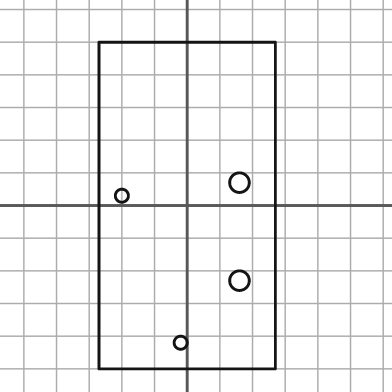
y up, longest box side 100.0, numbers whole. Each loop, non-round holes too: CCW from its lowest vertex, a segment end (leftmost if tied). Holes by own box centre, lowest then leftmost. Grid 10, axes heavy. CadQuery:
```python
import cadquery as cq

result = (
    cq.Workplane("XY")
    .moveTo(-27.0, -50.0)
    .lineTo(27.0, -50.0)
    .lineTo(27.0, 50.0)
    .lineTo(-27.0, 50.0)
    .close()
    .moveTo(-2.0, -42.0)
    .circle(2.0)
    .moveTo(16.0, -23.0)
    .circle(3.0)
    .moveTo(-20.0, 3.0)
    .circle(2.0)
    .moveTo(16.0, 7.0)
    .circle(3.0)
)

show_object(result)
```